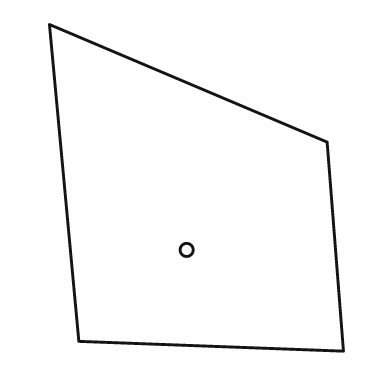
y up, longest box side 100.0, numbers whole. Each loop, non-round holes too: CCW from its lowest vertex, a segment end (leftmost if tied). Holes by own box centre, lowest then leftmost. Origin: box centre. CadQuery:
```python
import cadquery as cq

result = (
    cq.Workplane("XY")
    .moveTo(45.0, -50.0)
    .lineTo(40.0, 14.0)
    .lineTo(-45.0, 50.0)
    .lineTo(-36.0, -47.0)
    .close()
    .moveTo(-3.0, -19.0)
    .circle(2.0)
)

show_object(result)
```